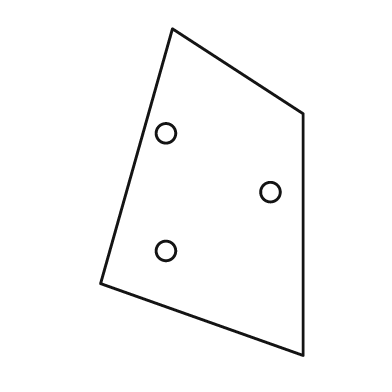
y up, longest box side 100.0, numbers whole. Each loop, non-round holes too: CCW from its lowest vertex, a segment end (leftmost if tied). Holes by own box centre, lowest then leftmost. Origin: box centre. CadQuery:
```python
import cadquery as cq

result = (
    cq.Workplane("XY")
    .moveTo(31.0, -50.0)
    .lineTo(31.0, 24.0)
    .lineTo(-9.0, 50.0)
    .lineTo(-31.0, -28.0)
    .close()
    .moveTo(-11.0, -18.0)
    .circle(3.0)
    .moveTo(21.0, 0.0)
    .circle(3.0)
    .moveTo(-11.0, 18.0)
    .circle(3.0)
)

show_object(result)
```